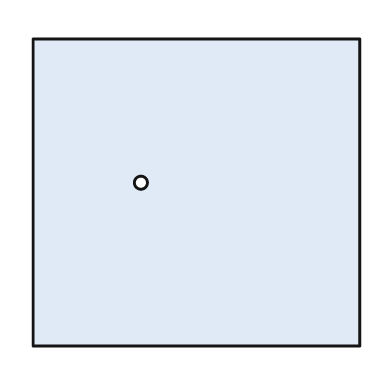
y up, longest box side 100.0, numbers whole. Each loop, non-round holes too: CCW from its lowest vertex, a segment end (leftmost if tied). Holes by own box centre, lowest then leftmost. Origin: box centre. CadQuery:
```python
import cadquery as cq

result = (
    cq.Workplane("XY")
    .moveTo(-50.0, -47.0)
    .lineTo(50.0, -47.0)
    .lineTo(50.0, 47.0)
    .lineTo(-50.0, 47.0)
    .close()
    .moveTo(-17.0, 3.0)
    .circle(2.0)
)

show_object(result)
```